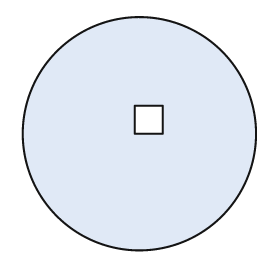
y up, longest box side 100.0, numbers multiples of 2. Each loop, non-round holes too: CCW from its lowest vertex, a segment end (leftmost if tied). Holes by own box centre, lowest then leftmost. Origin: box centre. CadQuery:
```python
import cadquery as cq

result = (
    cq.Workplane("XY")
    .moveTo(0.0, 0.0)
    .circle(50.0)
    .moveTo(-2.0, 0.0)
    .lineTo(10.0, 0.0)
    .lineTo(10.0, 12.0)
    .lineTo(-2.0, 12.0)
    .close()
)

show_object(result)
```